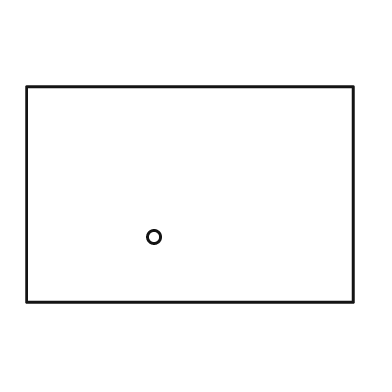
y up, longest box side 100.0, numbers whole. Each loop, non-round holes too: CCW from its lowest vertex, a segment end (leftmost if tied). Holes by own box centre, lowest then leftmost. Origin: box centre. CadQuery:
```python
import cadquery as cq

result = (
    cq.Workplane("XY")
    .moveTo(-50.0, -33.0)
    .lineTo(50.0, -33.0)
    .lineTo(50.0, 33.0)
    .lineTo(-50.0, 33.0)
    .close()
    .moveTo(-11.0, -13.0)
    .circle(2.0)
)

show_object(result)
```